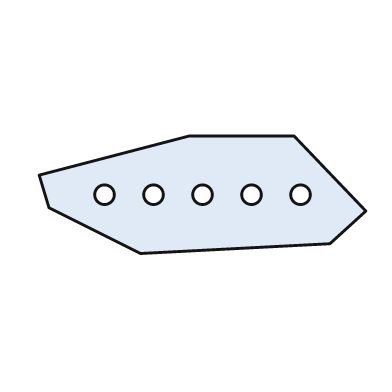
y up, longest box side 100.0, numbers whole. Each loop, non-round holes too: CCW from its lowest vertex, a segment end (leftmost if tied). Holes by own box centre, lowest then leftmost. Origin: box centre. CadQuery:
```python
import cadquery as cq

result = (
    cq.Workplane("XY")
    .moveTo(-19.0, -18.0)
    .lineTo(39.0, -15.0)
    .lineTo(50.0, -5.0)
    .lineTo(28.0, 18.0)
    .lineTo(-4.0, 18.0)
    .lineTo(-50.0, 6.0)
    .lineTo(-47.0, -4.0)
    .close()
    .moveTo(-30.0, 0.0)
    .circle(3.0)
    .moveTo(-15.0, 0.0)
    .circle(3.0)
    .moveTo(0.0, 0.0)
    .circle(3.0)
    .moveTo(15.0, 0.0)
    .circle(3.0)
    .moveTo(30.0, 0.0)
    .circle(3.0)
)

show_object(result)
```